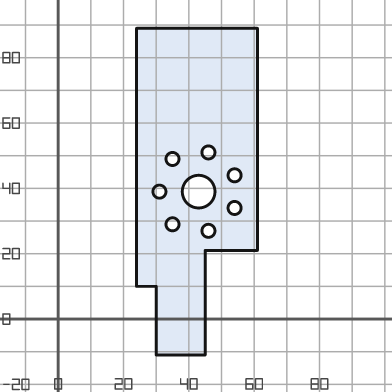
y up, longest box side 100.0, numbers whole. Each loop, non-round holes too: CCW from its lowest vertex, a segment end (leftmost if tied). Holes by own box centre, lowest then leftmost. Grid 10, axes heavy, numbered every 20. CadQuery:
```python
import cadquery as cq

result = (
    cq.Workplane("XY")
    .moveTo(30.0, -11.0)
    .lineTo(45.0, -11.0)
    .lineTo(45.0, 21.0)
    .lineTo(61.0, 21.0)
    .lineTo(61.0, 89.0)
    .lineTo(24.0, 89.0)
    .lineTo(24.0, 10.0)
    .lineTo(30.0, 10.0)
    .close()
    .moveTo(46.0, 27.0)
    .circle(2.0)
    .moveTo(35.0, 29.0)
    .circle(2.0)
    .moveTo(54.0, 34.0)
    .circle(2.0)
    .moveTo(31.0, 39.0)
    .circle(2.0)
    .moveTo(43.0, 39.0)
    .circle(5.0)
    .moveTo(54.0, 44.0)
    .circle(2.0)
    .moveTo(35.0, 49.0)
    .circle(2.0)
    .moveTo(46.0, 51.0)
    .circle(2.0)
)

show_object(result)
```